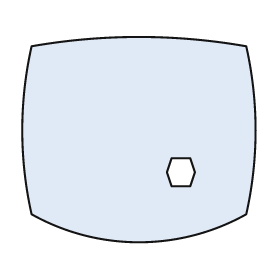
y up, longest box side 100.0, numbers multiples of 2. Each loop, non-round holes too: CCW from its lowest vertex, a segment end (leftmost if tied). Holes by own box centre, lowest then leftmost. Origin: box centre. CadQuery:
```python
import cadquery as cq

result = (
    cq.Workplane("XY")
    .moveTo(-46.0, -32.0)
    .threePointArc((0.0, -44.0), (46.0, -32.0))
    .threePointArc((50.0, 4.0), (46.0, 40.0))
    .threePointArc((0.0, 44.0), (-46.0, 40.0))
    .threePointArc((-50.0, 4.0), (-46.0, -32.0))
    .close()
    .moveTo(14.0, -20.0)
    .lineTo(22.0, -20.0)
    .lineTo(24.0, -14.0)
    .lineTo(22.0, -8.0)
    .lineTo(14.0, -8.0)
    .lineTo(12.0, -14.0)
    .close()
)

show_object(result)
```